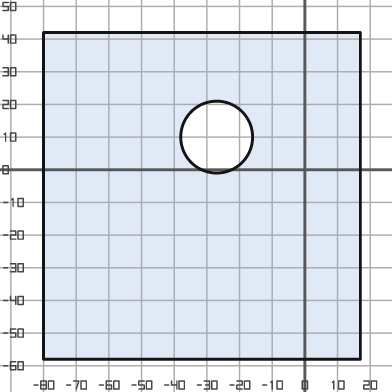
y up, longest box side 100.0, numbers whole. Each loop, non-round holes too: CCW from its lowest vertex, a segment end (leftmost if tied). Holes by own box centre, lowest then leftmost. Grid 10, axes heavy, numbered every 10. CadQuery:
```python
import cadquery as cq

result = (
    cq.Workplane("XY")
    .moveTo(-80.0, -58.0)
    .lineTo(17.0, -58.0)
    .lineTo(17.0, 42.0)
    .lineTo(-80.0, 42.0)
    .close()
    .moveTo(-27.0, 10.0)
    .circle(11.0)
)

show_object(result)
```